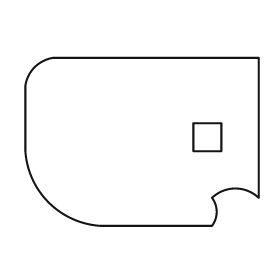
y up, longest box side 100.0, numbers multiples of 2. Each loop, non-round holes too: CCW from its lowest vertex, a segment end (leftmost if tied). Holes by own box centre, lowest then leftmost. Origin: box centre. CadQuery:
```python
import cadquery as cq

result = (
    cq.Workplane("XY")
    .moveTo(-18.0, -36.0)
    .lineTo(30.0, -36.0)
    .threePointArc((32.0, -30.0), (30.0, -24.0))
    .threePointArc((40.0, -20.0), (50.0, -24.0))
    .lineTo(50.0, 36.0)
    .lineTo(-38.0, 36.0)
    .threePointArc((-46.0, 32.0), (-50.0, 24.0))
    .lineTo(-50.0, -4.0)
    .threePointArc((-40.0, -26.0), (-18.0, -36.0))
    .close()
    .moveTo(22.0, -4.0)
    .lineTo(34.0, -4.0)
    .lineTo(34.0, 8.0)
    .lineTo(22.0, 8.0)
    .close()
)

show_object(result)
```